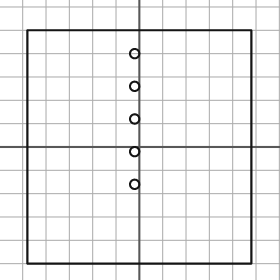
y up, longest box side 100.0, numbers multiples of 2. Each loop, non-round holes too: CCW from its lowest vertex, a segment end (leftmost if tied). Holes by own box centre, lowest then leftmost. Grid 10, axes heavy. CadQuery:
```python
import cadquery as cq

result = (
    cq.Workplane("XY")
    .moveTo(-48.0, -50.0)
    .lineTo(48.0, -50.0)
    .lineTo(48.0, 50.0)
    .lineTo(-48.0, 50.0)
    .close()
    .moveTo(-2.0, -16.0)
    .circle(2.0)
    .moveTo(-2.0, -2.0)
    .circle(2.0)
    .moveTo(-2.0, 12.0)
    .circle(2.0)
    .moveTo(-2.0, 26.0)
    .circle(2.0)
    .moveTo(-2.0, 40.0)
    .circle(2.0)
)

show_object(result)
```